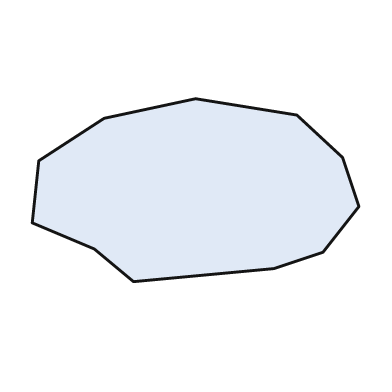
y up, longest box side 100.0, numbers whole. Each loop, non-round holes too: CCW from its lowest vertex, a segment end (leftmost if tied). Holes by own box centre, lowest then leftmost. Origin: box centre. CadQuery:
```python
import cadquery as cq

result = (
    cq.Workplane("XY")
    .moveTo(-19.0, -28.0)
    .lineTo(24.0, -24.0)
    .lineTo(39.0, -19.0)
    .lineTo(50.0, -5.0)
    .lineTo(45.0, 10.0)
    .lineTo(31.0, 23.0)
    .lineTo(0.0, 28.0)
    .lineTo(-28.0, 22.0)
    .lineTo(-48.0, 9.0)
    .lineTo(-50.0, -10.0)
    .lineTo(-31.0, -18.0)
    .close()
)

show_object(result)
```